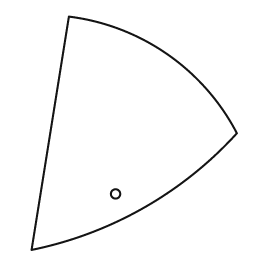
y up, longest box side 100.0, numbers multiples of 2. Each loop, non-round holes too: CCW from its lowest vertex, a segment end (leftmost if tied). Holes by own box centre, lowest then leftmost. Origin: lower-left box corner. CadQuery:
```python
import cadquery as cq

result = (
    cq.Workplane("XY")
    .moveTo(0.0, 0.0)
    .threePointArc((48.0, 18.0), (88.0, 50.0))
    .threePointArc((58.0, 84.0), (16.0, 100.0))
    .close()
    .moveTo(36.0, 24.0)
    .circle(2.0)
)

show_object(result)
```